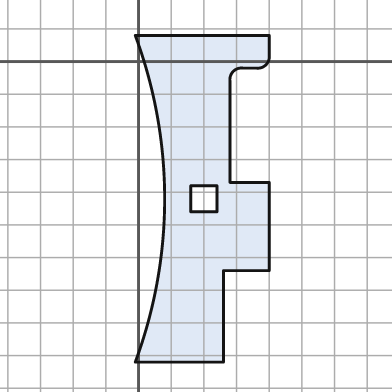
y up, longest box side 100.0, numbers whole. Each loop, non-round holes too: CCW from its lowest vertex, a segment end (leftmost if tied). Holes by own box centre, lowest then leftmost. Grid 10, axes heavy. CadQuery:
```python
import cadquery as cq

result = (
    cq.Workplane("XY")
    .moveTo(-1.0, -92.0)
    .lineTo(26.0, -92.0)
    .lineTo(26.0, -64.0)
    .lineTo(40.0, -64.0)
    .lineTo(40.0, -37.0)
    .lineTo(28.0, -37.0)
    .lineTo(28.0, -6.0)
    .threePointArc((29.0, -3.0), (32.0, -2.0))
    .lineTo(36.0, -2.0)
    .threePointArc((39.0, -1.0), (40.0, 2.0))
    .lineTo(40.0, 8.0)
    .lineTo(-1.0, 8.0)
    .threePointArc((8.0, -42.0), (-1.0, -92.0))
    .close()
    .moveTo(16.0, -46.0)
    .lineTo(24.0, -46.0)
    .lineTo(24.0, -38.0)
    .lineTo(16.0, -38.0)
    .close()
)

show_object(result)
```